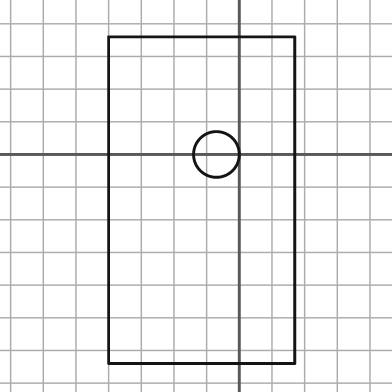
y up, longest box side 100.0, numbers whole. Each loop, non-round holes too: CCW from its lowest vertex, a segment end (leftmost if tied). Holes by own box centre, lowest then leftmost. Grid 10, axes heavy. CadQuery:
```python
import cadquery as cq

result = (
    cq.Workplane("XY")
    .moveTo(-40.0, -64.0)
    .lineTo(17.0, -64.0)
    .lineTo(17.0, 36.0)
    .lineTo(-40.0, 36.0)
    .close()
    .moveTo(-7.0, 0.0)
    .circle(7.0)
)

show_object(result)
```